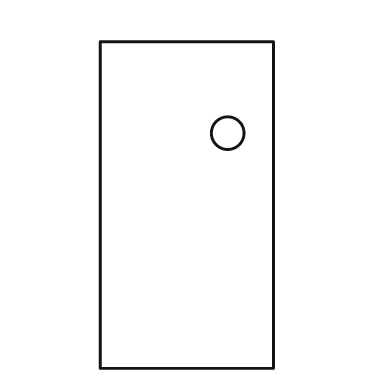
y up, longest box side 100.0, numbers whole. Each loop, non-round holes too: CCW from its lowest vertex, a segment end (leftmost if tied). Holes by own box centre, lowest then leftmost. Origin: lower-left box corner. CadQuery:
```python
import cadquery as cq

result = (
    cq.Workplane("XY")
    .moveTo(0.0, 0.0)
    .lineTo(53.0, 0.0)
    .lineTo(53.0, 100.0)
    .lineTo(0.0, 100.0)
    .close()
    .moveTo(39.0, 72.0)
    .circle(5.0)
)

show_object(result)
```